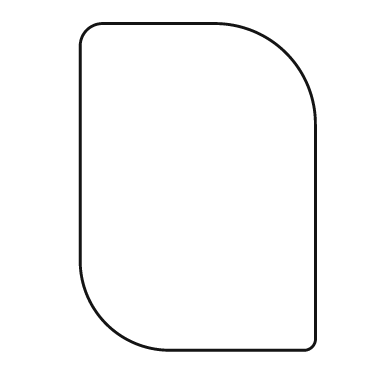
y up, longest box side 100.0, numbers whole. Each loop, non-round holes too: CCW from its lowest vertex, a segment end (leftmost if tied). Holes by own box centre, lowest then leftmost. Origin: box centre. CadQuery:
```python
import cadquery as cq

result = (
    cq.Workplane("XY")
    .moveTo(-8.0, -50.0)
    .lineTo(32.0, -50.0)
    .threePointArc((35.0, -49.0), (36.0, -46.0))
    .lineTo(36.0, 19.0)
    .threePointArc((27.0, 41.0), (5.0, 50.0))
    .lineTo(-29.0, 50.0)
    .threePointArc((-34.0, 48.0), (-36.0, 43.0))
    .lineTo(-36.0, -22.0)
    .threePointArc((-28.0, -42.0), (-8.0, -50.0))
    .close()
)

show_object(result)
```